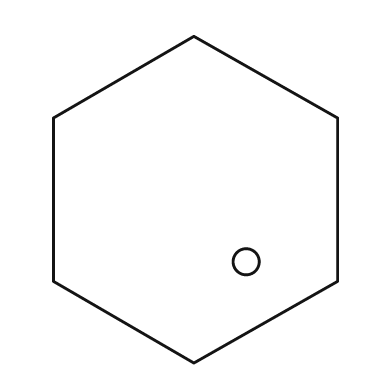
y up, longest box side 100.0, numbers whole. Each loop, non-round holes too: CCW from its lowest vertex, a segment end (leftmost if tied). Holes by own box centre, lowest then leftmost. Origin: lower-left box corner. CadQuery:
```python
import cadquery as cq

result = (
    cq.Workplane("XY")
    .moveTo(43.0, 0.0)
    .lineTo(87.0, 25.0)
    .lineTo(87.0, 75.0)
    .lineTo(43.0, 100.0)
    .lineTo(0.0, 75.0)
    .lineTo(0.0, 25.0)
    .close()
    .moveTo(59.0, 31.0)
    .circle(4.0)
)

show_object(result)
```